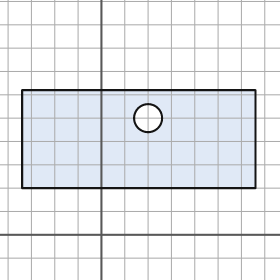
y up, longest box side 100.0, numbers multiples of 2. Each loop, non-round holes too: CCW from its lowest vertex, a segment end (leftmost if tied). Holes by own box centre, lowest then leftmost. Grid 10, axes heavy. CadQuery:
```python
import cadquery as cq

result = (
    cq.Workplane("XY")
    .moveTo(-34.0, 20.0)
    .lineTo(66.0, 20.0)
    .lineTo(66.0, 62.0)
    .lineTo(-34.0, 62.0)
    .close()
    .moveTo(20.0, 50.0)
    .circle(6.0)
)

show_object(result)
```